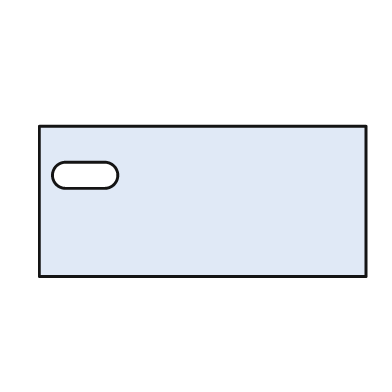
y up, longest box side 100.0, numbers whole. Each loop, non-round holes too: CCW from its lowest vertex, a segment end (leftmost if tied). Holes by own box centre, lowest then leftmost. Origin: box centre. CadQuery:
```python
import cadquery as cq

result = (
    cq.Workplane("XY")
    .moveTo(-50.0, -23.0)
    .lineTo(50.0, -23.0)
    .lineTo(50.0, 23.0)
    .lineTo(-50.0, 23.0)
    .close()
    .moveTo(-42.0, 4.0)
    .lineTo(-30.0, 4.0)
    .threePointArc((-26.0, 8.0), (-30.0, 12.0))
    .lineTo(-42.0, 12.0)
    .threePointArc((-46.0, 8.0), (-42.0, 4.0))
    .close()
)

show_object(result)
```